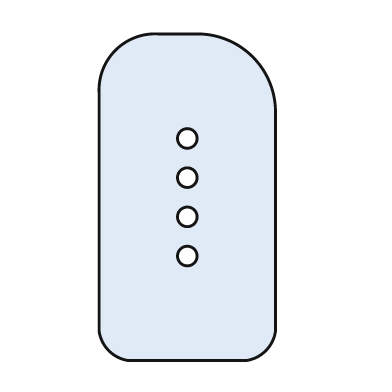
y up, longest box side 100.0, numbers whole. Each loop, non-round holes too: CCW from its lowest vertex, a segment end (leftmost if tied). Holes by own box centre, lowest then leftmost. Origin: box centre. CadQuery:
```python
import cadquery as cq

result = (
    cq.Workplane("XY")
    .moveTo(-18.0, -50.0)
    .lineTo(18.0, -50.0)
    .threePointArc((24.0, -47.0), (27.0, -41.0))
    .lineTo(27.0, 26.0)
    .threePointArc((20.0, 43.0), (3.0, 50.0))
    .lineTo(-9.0, 50.0)
    .threePointArc((-22.0, 45.0), (-27.0, 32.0))
    .lineTo(-27.0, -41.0)
    .threePointArc((-24.0, -47.0), (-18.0, -50.0))
    .close()
    .moveTo(0.0, -18.0)
    .circle(3.0)
    .moveTo(0.0, -6.0)
    .circle(3.0)
    .moveTo(0.0, 6.0)
    .circle(3.0)
    .moveTo(0.0, 18.0)
    .circle(3.0)
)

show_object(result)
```